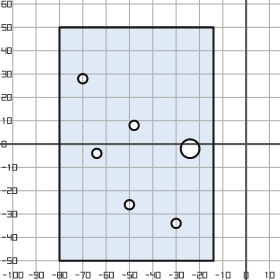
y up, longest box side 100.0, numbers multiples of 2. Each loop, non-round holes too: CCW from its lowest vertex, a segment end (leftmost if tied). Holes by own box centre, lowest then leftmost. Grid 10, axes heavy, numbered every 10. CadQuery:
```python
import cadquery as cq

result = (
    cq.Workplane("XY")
    .moveTo(-80.0, -50.0)
    .lineTo(-14.0, -50.0)
    .lineTo(-14.0, 50.0)
    .lineTo(-80.0, 50.0)
    .close()
    .moveTo(-30.0, -34.0)
    .circle(2.0)
    .moveTo(-50.0, -26.0)
    .circle(2.0)
    .moveTo(-64.0, -4.0)
    .circle(2.0)
    .moveTo(-24.0, -2.0)
    .circle(4.0)
    .moveTo(-48.0, 8.0)
    .circle(2.0)
    .moveTo(-70.0, 28.0)
    .circle(2.0)
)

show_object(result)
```